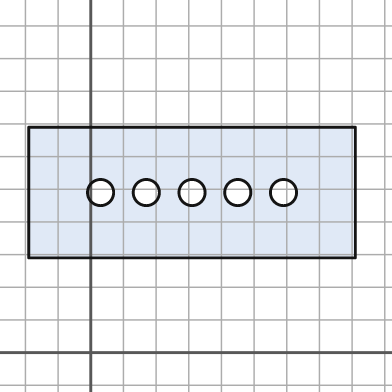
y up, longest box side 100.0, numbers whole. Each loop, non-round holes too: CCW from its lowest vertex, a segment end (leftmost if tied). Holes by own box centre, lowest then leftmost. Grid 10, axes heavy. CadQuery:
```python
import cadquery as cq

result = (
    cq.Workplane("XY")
    .moveTo(-19.0, 29.0)
    .lineTo(81.0, 29.0)
    .lineTo(81.0, 69.0)
    .lineTo(-19.0, 69.0)
    .close()
    .moveTo(3.0, 49.0)
    .circle(4.0)
    .moveTo(17.0, 49.0)
    .circle(4.0)
    .moveTo(31.0, 49.0)
    .circle(4.0)
    .moveTo(45.0, 49.0)
    .circle(4.0)
    .moveTo(59.0, 49.0)
    .circle(4.0)
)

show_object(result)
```